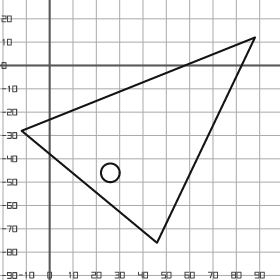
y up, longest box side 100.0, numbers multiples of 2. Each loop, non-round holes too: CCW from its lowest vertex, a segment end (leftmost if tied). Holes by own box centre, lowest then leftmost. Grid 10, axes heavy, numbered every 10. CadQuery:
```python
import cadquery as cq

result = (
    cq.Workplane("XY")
    .moveTo(46.0, -76.0)
    .lineTo(88.0, 12.0)
    .lineTo(-12.0, -28.0)
    .close()
    .moveTo(26.0, -46.0)
    .circle(4.0)
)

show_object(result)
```